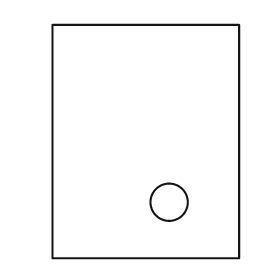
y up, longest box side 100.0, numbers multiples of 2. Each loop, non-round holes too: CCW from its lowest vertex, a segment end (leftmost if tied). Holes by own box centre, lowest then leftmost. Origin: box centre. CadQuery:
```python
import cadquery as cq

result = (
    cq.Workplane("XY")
    .moveTo(-40.0, -50.0)
    .lineTo(40.0, -50.0)
    .lineTo(40.0, 50.0)
    .lineTo(-40.0, 50.0)
    .close()
    .moveTo(10.0, -26.0)
    .circle(8.0)
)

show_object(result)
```